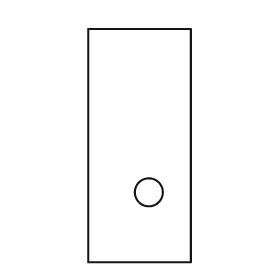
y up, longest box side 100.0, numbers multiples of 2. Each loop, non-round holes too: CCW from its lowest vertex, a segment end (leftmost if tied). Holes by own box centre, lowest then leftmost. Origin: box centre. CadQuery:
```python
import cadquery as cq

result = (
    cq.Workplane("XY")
    .moveTo(-22.0, -50.0)
    .lineTo(22.0, -50.0)
    .lineTo(22.0, 50.0)
    .lineTo(-22.0, 50.0)
    .close()
    .moveTo(4.0, -20.0)
    .circle(6.0)
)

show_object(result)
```